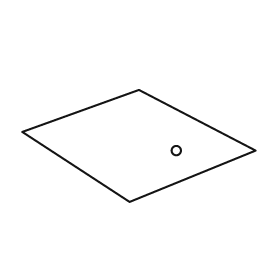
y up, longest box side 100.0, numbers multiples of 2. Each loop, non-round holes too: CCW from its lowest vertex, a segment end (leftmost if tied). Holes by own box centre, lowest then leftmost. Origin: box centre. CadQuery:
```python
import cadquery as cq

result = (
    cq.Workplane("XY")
    .moveTo(-4.0, -24.0)
    .lineTo(50.0, -2.0)
    .lineTo(0.0, 24.0)
    .lineTo(-50.0, 6.0)
    .close()
    .moveTo(16.0, -2.0)
    .circle(2.0)
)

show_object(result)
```